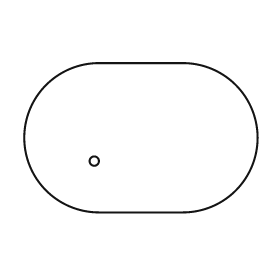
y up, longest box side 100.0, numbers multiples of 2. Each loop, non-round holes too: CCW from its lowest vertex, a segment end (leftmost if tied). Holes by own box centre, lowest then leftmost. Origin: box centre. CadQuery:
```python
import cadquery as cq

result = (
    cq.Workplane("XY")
    .moveTo(-18.0, -32.0)
    .lineTo(18.0, -32.0)
    .threePointArc((50.0, 0.0), (18.0, 32.0))
    .lineTo(-18.0, 32.0)
    .threePointArc((-50.0, 0.0), (-18.0, -32.0))
    .close()
    .moveTo(-20.0, -10.0)
    .circle(2.0)
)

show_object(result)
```